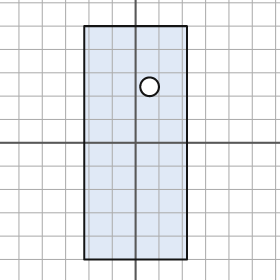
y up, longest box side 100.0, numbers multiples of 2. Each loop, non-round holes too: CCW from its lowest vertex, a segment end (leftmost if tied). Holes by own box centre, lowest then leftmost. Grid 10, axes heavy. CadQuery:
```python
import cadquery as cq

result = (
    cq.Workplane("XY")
    .moveTo(-22.0, -50.0)
    .lineTo(22.0, -50.0)
    .lineTo(22.0, 50.0)
    .lineTo(-22.0, 50.0)
    .close()
    .moveTo(6.0, 24.0)
    .circle(4.0)
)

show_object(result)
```